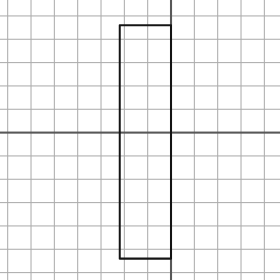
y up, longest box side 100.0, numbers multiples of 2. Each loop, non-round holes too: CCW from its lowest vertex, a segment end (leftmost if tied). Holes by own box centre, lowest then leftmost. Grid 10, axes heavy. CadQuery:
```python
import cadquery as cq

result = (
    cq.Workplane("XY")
    .moveTo(-22.0, -54.0)
    .lineTo(0.0, -54.0)
    .lineTo(0.0, 46.0)
    .lineTo(-22.0, 46.0)
    .close()
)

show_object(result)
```